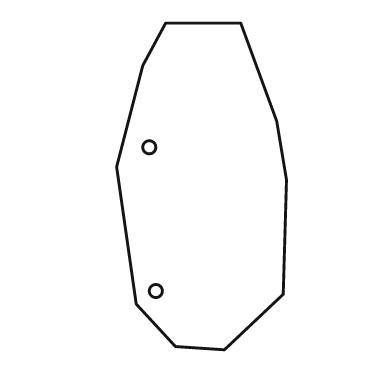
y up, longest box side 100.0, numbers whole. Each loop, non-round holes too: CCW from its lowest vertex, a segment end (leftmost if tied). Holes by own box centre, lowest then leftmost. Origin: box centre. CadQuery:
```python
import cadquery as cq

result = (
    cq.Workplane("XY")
    .moveTo(7.0, -50.0)
    .lineTo(25.0, -33.0)
    .lineTo(26.0, 2.0)
    .lineTo(23.0, 20.0)
    .lineTo(12.0, 50.0)
    .lineTo(-11.0, 50.0)
    .lineTo(-18.0, 37.0)
    .lineTo(-26.0, 6.0)
    .lineTo(-20.0, -36.0)
    .lineTo(-8.0, -49.0)
    .close()
    .moveTo(-14.0, -32.0)
    .circle(2.0)
    .moveTo(-16.0, 12.0)
    .circle(2.0)
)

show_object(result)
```